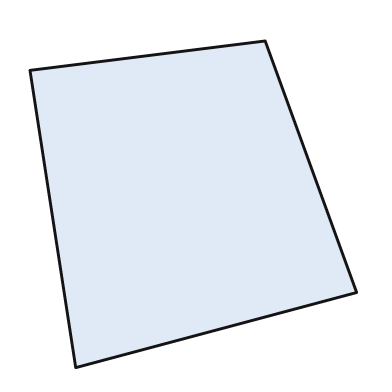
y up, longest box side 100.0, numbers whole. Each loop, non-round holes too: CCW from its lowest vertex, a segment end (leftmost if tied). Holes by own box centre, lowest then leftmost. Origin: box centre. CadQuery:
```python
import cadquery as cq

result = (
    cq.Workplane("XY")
    .moveTo(-36.0, -50.0)
    .lineTo(50.0, -27.0)
    .lineTo(22.0, 50.0)
    .lineTo(-50.0, 41.0)
    .close()
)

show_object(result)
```